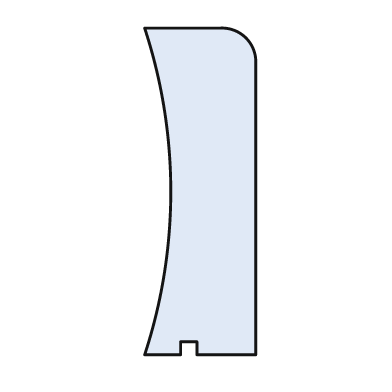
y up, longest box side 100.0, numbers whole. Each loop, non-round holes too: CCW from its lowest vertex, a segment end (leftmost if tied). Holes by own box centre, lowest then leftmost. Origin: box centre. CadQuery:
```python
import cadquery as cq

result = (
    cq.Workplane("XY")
    .moveTo(-17.0, -50.0)
    .lineTo(-6.0, -50.0)
    .lineTo(-6.0, -46.0)
    .lineTo(-1.0, -46.0)
    .lineTo(-1.0, -50.0)
    .lineTo(17.0, -50.0)
    .lineTo(17.0, 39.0)
    .threePointArc((14.0, 47.0), (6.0, 50.0))
    .lineTo(-17.0, 50.0)
    .threePointArc((-9.0, 0.0), (-17.0, -50.0))
    .close()
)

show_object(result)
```